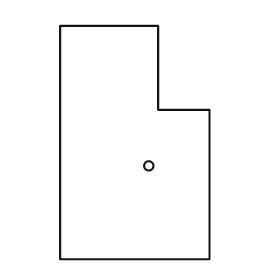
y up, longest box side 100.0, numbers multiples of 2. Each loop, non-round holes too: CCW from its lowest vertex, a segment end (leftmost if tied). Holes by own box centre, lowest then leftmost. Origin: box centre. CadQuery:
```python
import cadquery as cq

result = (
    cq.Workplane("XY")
    .moveTo(-32.0, -50.0)
    .lineTo(32.0, -50.0)
    .lineTo(32.0, 14.0)
    .lineTo(10.0, 14.0)
    .lineTo(10.0, 50.0)
    .lineTo(-32.0, 50.0)
    .close()
    .moveTo(6.0, -10.0)
    .circle(2.0)
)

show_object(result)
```